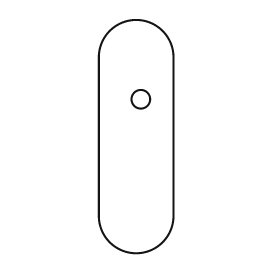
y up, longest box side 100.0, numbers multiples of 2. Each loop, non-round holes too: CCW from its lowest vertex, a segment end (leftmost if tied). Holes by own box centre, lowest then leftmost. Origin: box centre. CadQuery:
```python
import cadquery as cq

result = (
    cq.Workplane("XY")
    .moveTo(-16.0, -34.0)
    .threePointArc((0.0, -50.0), (16.0, -34.0))
    .lineTo(16.0, 34.0)
    .threePointArc((0.0, 50.0), (-16.0, 34.0))
    .close()
    .moveTo(2.0, 16.0)
    .circle(4.0)
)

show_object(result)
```